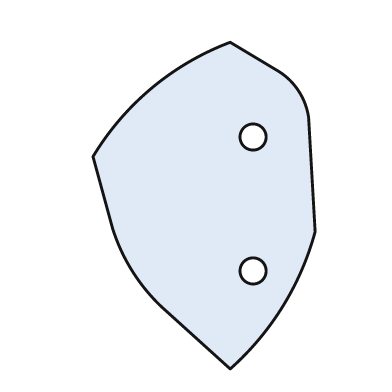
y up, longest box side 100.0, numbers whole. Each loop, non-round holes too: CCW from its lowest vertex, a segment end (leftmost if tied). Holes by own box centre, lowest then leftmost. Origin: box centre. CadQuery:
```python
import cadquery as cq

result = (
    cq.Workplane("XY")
    .moveTo(8.0, -50.0)
    .threePointArc((24.0, -31.0), (34.0, -8.0))
    .lineTo(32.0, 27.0)
    .threePointArc((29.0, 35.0), (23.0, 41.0))
    .lineTo(8.0, 50.0)
    .threePointArc((-16.0, 36.0), (-34.0, 15.0))
    .lineTo(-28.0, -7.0)
    .threePointArc((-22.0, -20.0), (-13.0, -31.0))
    .close()
    .moveTo(15.0, -20.0)
    .circle(4.0)
    .moveTo(15.0, 21.0)
    .circle(4.0)
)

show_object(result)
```